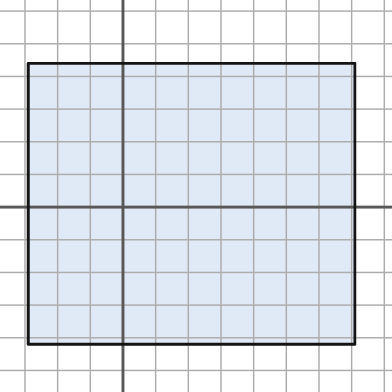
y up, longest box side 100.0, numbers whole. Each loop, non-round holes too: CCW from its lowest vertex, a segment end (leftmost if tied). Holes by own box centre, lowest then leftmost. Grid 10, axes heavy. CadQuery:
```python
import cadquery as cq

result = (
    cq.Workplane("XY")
    .moveTo(-29.0, -42.0)
    .lineTo(71.0, -42.0)
    .lineTo(71.0, 44.0)
    .lineTo(-29.0, 44.0)
    .close()
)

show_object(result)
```